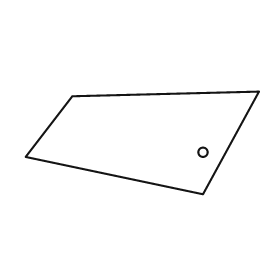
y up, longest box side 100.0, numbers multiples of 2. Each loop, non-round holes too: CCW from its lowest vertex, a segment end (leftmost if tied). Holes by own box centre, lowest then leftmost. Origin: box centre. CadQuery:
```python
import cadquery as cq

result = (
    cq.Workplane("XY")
    .moveTo(26.0, -22.0)
    .lineTo(50.0, 22.0)
    .lineTo(-30.0, 20.0)
    .lineTo(-50.0, -6.0)
    .close()
    .moveTo(26.0, -4.0)
    .circle(2.0)
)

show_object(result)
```